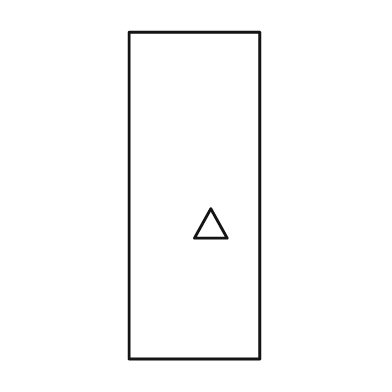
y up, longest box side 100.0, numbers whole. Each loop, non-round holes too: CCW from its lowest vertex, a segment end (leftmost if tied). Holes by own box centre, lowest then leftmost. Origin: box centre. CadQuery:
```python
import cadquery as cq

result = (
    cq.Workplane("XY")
    .moveTo(-20.0, -50.0)
    .lineTo(20.0, -50.0)
    .lineTo(20.0, 50.0)
    .lineTo(-20.0, 50.0)
    .close()
    .moveTo(0.0, -13.0)
    .lineTo(10.0, -13.0)
    .lineTo(5.0, -4.0)
    .close()
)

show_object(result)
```